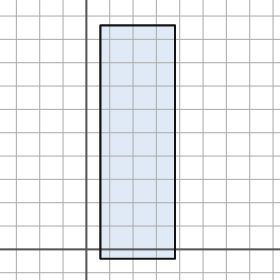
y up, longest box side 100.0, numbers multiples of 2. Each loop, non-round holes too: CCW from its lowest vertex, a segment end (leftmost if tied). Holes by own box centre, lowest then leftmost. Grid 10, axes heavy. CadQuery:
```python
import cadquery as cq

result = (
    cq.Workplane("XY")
    .moveTo(6.0, -4.0)
    .lineTo(38.0, -4.0)
    .lineTo(38.0, 96.0)
    .lineTo(6.0, 96.0)
    .close()
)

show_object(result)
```